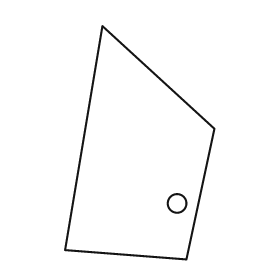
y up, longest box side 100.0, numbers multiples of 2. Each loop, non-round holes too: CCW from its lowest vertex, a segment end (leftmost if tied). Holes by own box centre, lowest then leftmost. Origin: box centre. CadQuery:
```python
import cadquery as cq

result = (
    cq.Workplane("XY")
    .moveTo(20.0, -50.0)
    .lineTo(32.0, 6.0)
    .lineTo(-16.0, 50.0)
    .lineTo(-32.0, -46.0)
    .close()
    .moveTo(16.0, -26.0)
    .circle(4.0)
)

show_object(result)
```